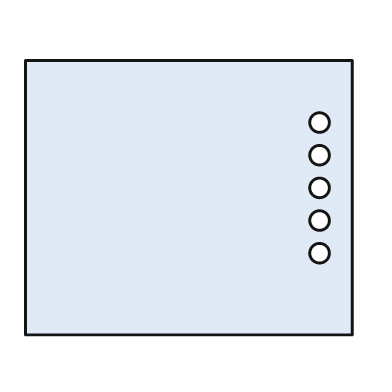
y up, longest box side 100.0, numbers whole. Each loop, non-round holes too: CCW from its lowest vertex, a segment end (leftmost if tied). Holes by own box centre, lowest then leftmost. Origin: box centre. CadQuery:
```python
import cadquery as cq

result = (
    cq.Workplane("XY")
    .moveTo(-50.0, -42.0)
    .lineTo(50.0, -42.0)
    .lineTo(50.0, 42.0)
    .lineTo(-50.0, 42.0)
    .close()
    .moveTo(40.0, -17.0)
    .circle(3.0)
    .moveTo(40.0, -7.0)
    .circle(3.0)
    .moveTo(40.0, 3.0)
    .circle(3.0)
    .moveTo(40.0, 13.0)
    .circle(3.0)
    .moveTo(40.0, 23.0)
    .circle(3.0)
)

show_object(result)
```